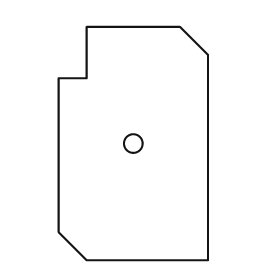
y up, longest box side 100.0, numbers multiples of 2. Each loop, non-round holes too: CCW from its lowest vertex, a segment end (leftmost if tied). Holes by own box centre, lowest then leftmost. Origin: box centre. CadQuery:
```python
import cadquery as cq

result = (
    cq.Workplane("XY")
    .moveTo(-20.0, -50.0)
    .lineTo(32.0, -50.0)
    .lineTo(32.0, 38.0)
    .lineTo(20.0, 50.0)
    .lineTo(-20.0, 50.0)
    .lineTo(-20.0, 28.0)
    .lineTo(-32.0, 28.0)
    .lineTo(-32.0, -38.0)
    .close()
    .moveTo(0.0, 0.0)
    .circle(4.0)
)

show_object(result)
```